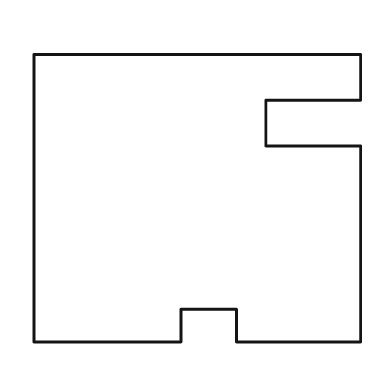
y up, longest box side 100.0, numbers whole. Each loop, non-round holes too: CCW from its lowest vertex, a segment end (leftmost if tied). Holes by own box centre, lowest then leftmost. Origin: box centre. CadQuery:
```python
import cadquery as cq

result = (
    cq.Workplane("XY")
    .moveTo(-50.0, -44.0)
    .lineTo(-5.0, -44.0)
    .lineTo(-5.0, -34.0)
    .lineTo(12.0, -34.0)
    .lineTo(12.0, -44.0)
    .lineTo(50.0, -44.0)
    .lineTo(50.0, 16.0)
    .lineTo(21.0, 16.0)
    .lineTo(21.0, 30.0)
    .lineTo(50.0, 30.0)
    .lineTo(50.0, 44.0)
    .lineTo(-50.0, 44.0)
    .close()
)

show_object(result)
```